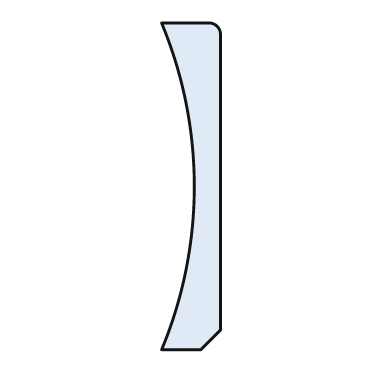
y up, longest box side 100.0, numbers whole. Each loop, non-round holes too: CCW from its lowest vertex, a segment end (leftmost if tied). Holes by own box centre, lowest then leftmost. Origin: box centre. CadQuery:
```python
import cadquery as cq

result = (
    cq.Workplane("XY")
    .moveTo(-9.0, -50.0)
    .lineTo(3.0, -50.0)
    .lineTo(9.0, -44.0)
    .lineTo(9.0, 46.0)
    .threePointArc((8.0, 49.0), (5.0, 50.0))
    .lineTo(-9.0, 50.0)
    .threePointArc((1.0, 0.0), (-9.0, -50.0))
    .close()
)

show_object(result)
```